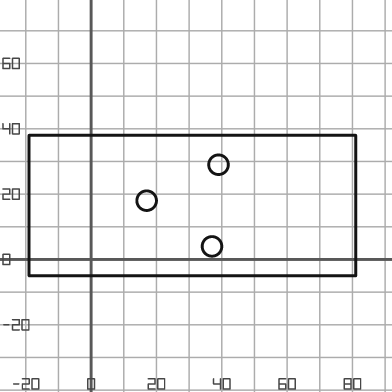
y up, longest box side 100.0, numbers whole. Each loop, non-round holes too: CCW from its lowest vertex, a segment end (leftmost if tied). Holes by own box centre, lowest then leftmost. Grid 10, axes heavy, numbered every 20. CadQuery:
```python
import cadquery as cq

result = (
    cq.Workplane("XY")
    .moveTo(-19.0, -5.0)
    .lineTo(81.0, -5.0)
    .lineTo(81.0, 38.0)
    .lineTo(-19.0, 38.0)
    .close()
    .moveTo(37.0, 4.0)
    .circle(3.0)
    .moveTo(17.0, 18.0)
    .circle(3.0)
    .moveTo(39.0, 29.0)
    .circle(3.0)
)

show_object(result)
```